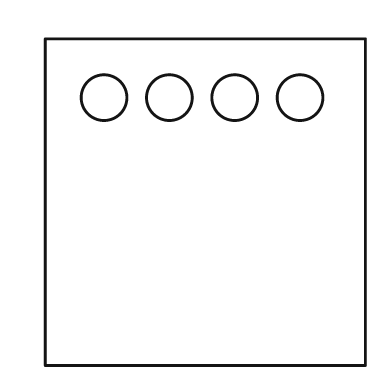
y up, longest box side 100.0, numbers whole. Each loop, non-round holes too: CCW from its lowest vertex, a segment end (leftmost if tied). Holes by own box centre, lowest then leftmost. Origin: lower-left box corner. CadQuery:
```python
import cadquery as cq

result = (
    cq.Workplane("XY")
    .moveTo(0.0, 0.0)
    .lineTo(98.0, 0.0)
    .lineTo(98.0, 100.0)
    .lineTo(0.0, 100.0)
    .close()
    .moveTo(18.0, 82.0)
    .circle(7.0)
    .moveTo(38.0, 82.0)
    .circle(7.0)
    .moveTo(58.0, 82.0)
    .circle(7.0)
    .moveTo(78.0, 82.0)
    .circle(7.0)
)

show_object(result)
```